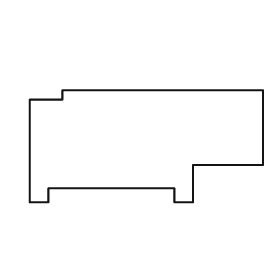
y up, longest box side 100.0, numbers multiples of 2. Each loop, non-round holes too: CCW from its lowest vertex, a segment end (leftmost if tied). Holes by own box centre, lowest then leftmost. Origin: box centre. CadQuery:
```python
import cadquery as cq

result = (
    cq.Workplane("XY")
    .moveTo(-50.0, -24.0)
    .lineTo(-42.0, -24.0)
    .lineTo(-42.0, -18.0)
    .lineTo(12.0, -18.0)
    .lineTo(12.0, -24.0)
    .lineTo(20.0, -24.0)
    .lineTo(20.0, -8.0)
    .lineTo(50.0, -8.0)
    .lineTo(50.0, 24.0)
    .lineTo(-36.0, 24.0)
    .lineTo(-36.0, 20.0)
    .lineTo(-50.0, 20.0)
    .close()
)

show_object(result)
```